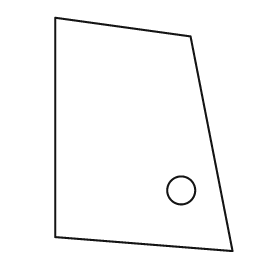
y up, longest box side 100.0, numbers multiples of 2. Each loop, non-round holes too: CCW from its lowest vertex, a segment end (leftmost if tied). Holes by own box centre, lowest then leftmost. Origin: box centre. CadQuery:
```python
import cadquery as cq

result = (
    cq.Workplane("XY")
    .moveTo(38.0, -50.0)
    .lineTo(20.0, 42.0)
    .lineTo(-38.0, 50.0)
    .lineTo(-38.0, -44.0)
    .close()
    .moveTo(16.0, -24.0)
    .circle(6.0)
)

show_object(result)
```